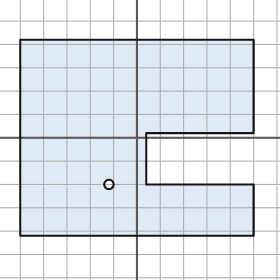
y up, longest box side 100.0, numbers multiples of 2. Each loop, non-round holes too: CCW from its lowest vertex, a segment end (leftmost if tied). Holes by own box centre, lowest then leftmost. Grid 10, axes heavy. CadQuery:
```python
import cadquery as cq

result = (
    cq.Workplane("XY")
    .moveTo(-50.0, -42.0)
    .lineTo(50.0, -42.0)
    .lineTo(50.0, -20.0)
    .lineTo(4.0, -20.0)
    .lineTo(4.0, 2.0)
    .lineTo(50.0, 2.0)
    .lineTo(50.0, 42.0)
    .lineTo(-50.0, 42.0)
    .close()
    .moveTo(-12.0, -20.0)
    .circle(2.0)
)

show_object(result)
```